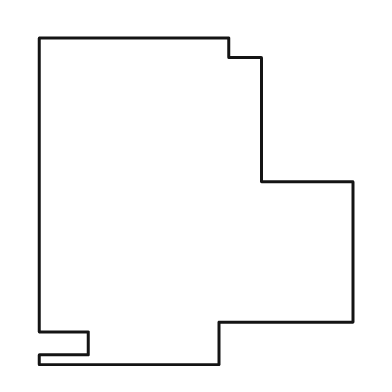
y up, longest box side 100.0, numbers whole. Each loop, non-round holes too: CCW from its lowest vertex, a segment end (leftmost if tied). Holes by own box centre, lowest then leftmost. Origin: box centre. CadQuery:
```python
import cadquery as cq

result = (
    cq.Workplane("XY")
    .moveTo(-48.0, -50.0)
    .lineTo(7.0, -50.0)
    .lineTo(7.0, -37.0)
    .lineTo(48.0, -37.0)
    .lineTo(48.0, 6.0)
    .lineTo(20.0, 6.0)
    .lineTo(20.0, 44.0)
    .lineTo(10.0, 44.0)
    .lineTo(10.0, 50.0)
    .lineTo(-48.0, 50.0)
    .lineTo(-48.0, -40.0)
    .lineTo(-33.0, -40.0)
    .lineTo(-33.0, -47.0)
    .lineTo(-48.0, -47.0)
    .close()
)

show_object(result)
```